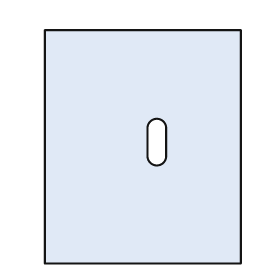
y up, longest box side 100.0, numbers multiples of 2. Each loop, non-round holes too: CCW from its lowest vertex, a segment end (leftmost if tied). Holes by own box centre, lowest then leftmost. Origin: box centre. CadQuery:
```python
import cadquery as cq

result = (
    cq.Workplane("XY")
    .moveTo(-42.0, -50.0)
    .lineTo(42.0, -50.0)
    .lineTo(42.0, 50.0)
    .lineTo(-42.0, 50.0)
    .close()
    .moveTo(2.0, -4.0)
    .threePointArc((6.0, -8.0), (10.0, -4.0))
    .lineTo(10.0, 8.0)
    .threePointArc((6.0, 12.0), (2.0, 8.0))
    .close()
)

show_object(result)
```